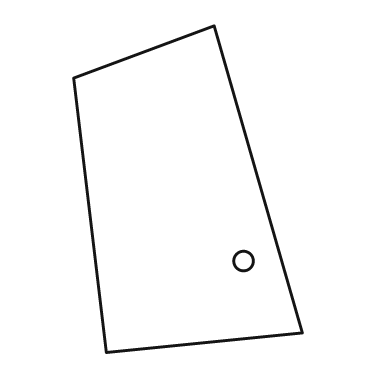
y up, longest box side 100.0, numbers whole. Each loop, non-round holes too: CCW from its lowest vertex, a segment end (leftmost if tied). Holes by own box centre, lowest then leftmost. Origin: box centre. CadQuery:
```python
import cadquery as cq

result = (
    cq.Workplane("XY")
    .moveTo(-25.0, -50.0)
    .lineTo(35.0, -44.0)
    .lineTo(8.0, 50.0)
    .lineTo(-35.0, 34.0)
    .close()
    .moveTo(17.0, -22.0)
    .circle(3.0)
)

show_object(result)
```